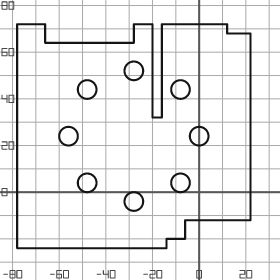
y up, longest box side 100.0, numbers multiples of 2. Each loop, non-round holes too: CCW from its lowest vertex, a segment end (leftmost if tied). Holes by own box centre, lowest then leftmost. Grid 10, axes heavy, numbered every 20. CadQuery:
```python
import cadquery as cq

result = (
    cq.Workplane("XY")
    .moveTo(-78.0, -24.0)
    .lineTo(-14.0, -24.0)
    .lineTo(-14.0, -20.0)
    .lineTo(-6.0, -20.0)
    .lineTo(-6.0, -12.0)
    .lineTo(22.0, -12.0)
    .lineTo(22.0, 68.0)
    .lineTo(12.0, 68.0)
    .lineTo(12.0, 72.0)
    .lineTo(-16.0, 72.0)
    .lineTo(-16.0, 32.0)
    .lineTo(-20.0, 32.0)
    .lineTo(-20.0, 72.0)
    .lineTo(-28.0, 72.0)
    .lineTo(-28.0, 64.0)
    .lineTo(-66.0, 64.0)
    .lineTo(-66.0, 72.0)
    .lineTo(-78.0, 72.0)
    .close()
    .moveTo(-28.0, -4.0)
    .circle(4.0)
    .moveTo(-48.0, 4.0)
    .circle(4.0)
    .moveTo(-8.0, 4.0)
    .circle(4.0)
    .moveTo(-56.0, 24.0)
    .circle(4.0)
    .moveTo(0.0, 24.0)
    .circle(4.0)
    .moveTo(-48.0, 44.0)
    .circle(4.0)
    .moveTo(-8.0, 44.0)
    .circle(4.0)
    .moveTo(-28.0, 52.0)
    .circle(4.0)
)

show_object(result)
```